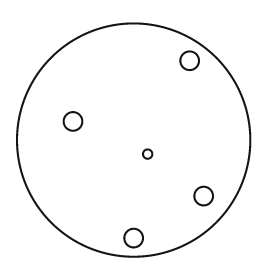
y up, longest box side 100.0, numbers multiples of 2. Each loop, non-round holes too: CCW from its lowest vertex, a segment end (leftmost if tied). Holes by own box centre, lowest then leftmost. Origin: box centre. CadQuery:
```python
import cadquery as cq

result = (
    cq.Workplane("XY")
    .moveTo(0.0, 0.0)
    .circle(50.0)
    .moveTo(0.0, -42.0)
    .circle(4.0)
    .moveTo(30.0, -24.0)
    .circle(4.0)
    .moveTo(6.0, -6.0)
    .circle(2.0)
    .moveTo(-26.0, 8.0)
    .circle(4.0)
    .moveTo(24.0, 34.0)
    .circle(4.0)
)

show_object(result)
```